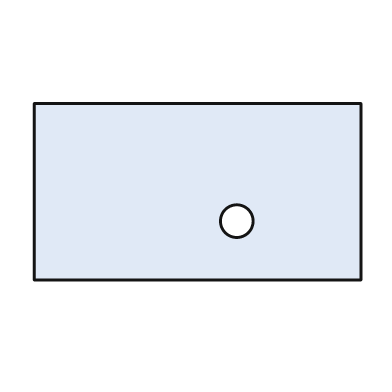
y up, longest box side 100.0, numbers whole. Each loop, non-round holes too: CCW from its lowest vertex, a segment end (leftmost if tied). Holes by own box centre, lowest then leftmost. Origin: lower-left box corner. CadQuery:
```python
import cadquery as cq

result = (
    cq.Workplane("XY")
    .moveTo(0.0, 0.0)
    .lineTo(100.0, 0.0)
    .lineTo(100.0, 54.0)
    .lineTo(0.0, 54.0)
    .close()
    .moveTo(62.0, 18.0)
    .circle(5.0)
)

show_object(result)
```